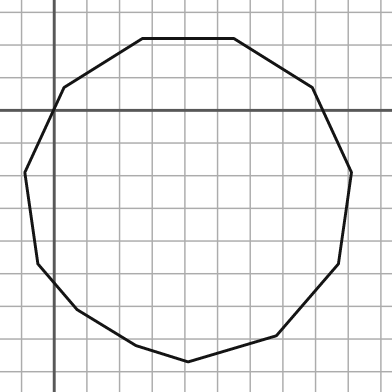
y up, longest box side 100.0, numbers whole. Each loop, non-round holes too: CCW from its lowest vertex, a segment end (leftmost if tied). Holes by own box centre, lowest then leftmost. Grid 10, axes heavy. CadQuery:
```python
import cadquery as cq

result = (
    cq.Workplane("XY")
    .moveTo(41.0, -77.0)
    .lineTo(68.0, -69.0)
    .lineTo(87.0, -47.0)
    .lineTo(91.0, -19.0)
    .lineTo(79.0, 7.0)
    .lineTo(55.0, 22.0)
    .lineTo(27.0, 22.0)
    .lineTo(3.0, 7.0)
    .lineTo(-9.0, -19.0)
    .lineTo(-5.0, -47.0)
    .lineTo(7.0, -61.0)
    .lineTo(25.0, -72.0)
    .close()
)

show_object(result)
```